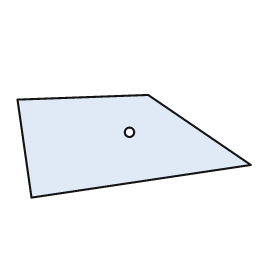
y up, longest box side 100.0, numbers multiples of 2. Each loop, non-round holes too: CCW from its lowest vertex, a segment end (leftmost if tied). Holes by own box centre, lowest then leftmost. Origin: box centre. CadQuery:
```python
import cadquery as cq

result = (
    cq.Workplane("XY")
    .moveTo(-44.0, -22.0)
    .lineTo(50.0, -8.0)
    .lineTo(6.0, 22.0)
    .lineTo(-50.0, 20.0)
    .close()
    .moveTo(-2.0, 6.0)
    .circle(2.0)
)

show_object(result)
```